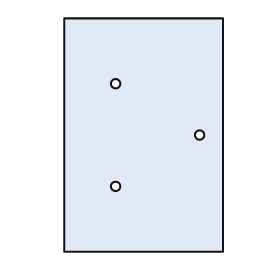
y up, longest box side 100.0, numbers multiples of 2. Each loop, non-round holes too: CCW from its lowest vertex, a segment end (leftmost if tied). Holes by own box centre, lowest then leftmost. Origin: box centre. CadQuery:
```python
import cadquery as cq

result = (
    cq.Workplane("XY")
    .moveTo(-34.0, -50.0)
    .lineTo(34.0, -50.0)
    .lineTo(34.0, 50.0)
    .lineTo(-34.0, 50.0)
    .close()
    .moveTo(-12.0, -22.0)
    .circle(2.0)
    .moveTo(24.0, 0.0)
    .circle(2.0)
    .moveTo(-12.0, 22.0)
    .circle(2.0)
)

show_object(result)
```